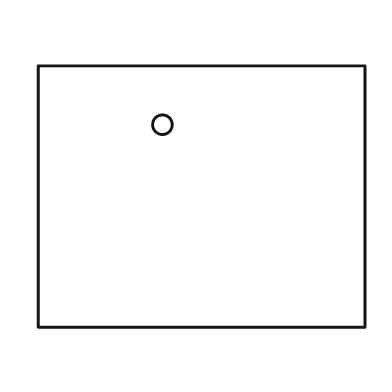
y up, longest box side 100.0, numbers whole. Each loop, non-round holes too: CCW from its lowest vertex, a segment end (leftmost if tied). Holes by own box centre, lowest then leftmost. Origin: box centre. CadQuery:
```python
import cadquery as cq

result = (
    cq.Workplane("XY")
    .moveTo(-50.0, -40.0)
    .lineTo(50.0, -40.0)
    .lineTo(50.0, 40.0)
    .lineTo(-50.0, 40.0)
    .close()
    .moveTo(-12.0, 22.0)
    .circle(3.0)
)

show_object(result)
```